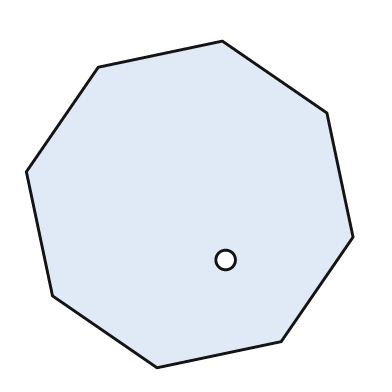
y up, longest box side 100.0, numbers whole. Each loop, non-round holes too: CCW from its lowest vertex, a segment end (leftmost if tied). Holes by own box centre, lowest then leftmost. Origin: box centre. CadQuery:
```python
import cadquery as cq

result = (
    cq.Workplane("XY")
    .moveTo(-10.0, -50.0)
    .lineTo(28.0, -42.0)
    .lineTo(50.0, -10.0)
    .lineTo(42.0, 28.0)
    .lineTo(10.0, 50.0)
    .lineTo(-28.0, 42.0)
    .lineTo(-50.0, 10.0)
    .lineTo(-42.0, -28.0)
    .close()
    .moveTo(11.0, -17.0)
    .circle(3.0)
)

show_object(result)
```